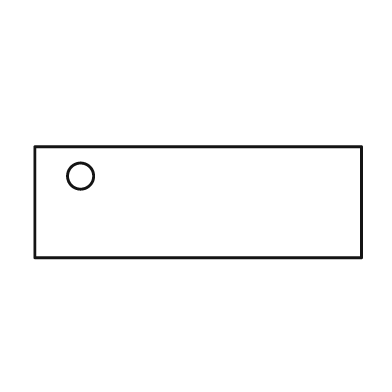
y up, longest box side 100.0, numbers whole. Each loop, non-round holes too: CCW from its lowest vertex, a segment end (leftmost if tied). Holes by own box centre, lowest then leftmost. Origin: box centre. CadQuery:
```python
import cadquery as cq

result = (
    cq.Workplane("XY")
    .moveTo(-50.0, -17.0)
    .lineTo(50.0, -17.0)
    .lineTo(50.0, 17.0)
    .lineTo(-50.0, 17.0)
    .close()
    .moveTo(-36.0, 8.0)
    .circle(4.0)
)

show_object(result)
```